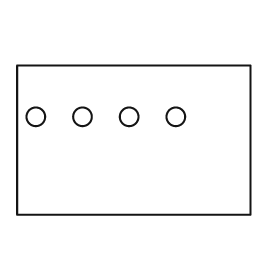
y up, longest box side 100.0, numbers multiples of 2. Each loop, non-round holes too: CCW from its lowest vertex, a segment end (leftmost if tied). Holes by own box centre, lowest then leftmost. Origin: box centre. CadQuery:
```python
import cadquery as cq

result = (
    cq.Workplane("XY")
    .moveTo(-50.0, -32.0)
    .lineTo(50.0, -32.0)
    .lineTo(50.0, 32.0)
    .lineTo(-50.0, 32.0)
    .close()
    .moveTo(-42.0, 10.0)
    .circle(4.0)
    .moveTo(-22.0, 10.0)
    .circle(4.0)
    .moveTo(-2.0, 10.0)
    .circle(4.0)
    .moveTo(18.0, 10.0)
    .circle(4.0)
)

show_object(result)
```